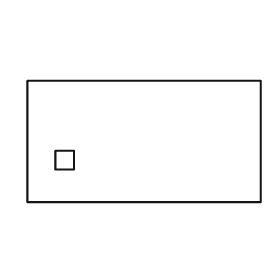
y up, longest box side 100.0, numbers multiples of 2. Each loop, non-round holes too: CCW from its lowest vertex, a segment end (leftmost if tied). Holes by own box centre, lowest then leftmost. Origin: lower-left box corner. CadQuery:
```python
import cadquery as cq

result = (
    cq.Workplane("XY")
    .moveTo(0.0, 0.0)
    .lineTo(100.0, 0.0)
    .lineTo(100.0, 52.0)
    .lineTo(0.0, 52.0)
    .close()
    .moveTo(12.0, 14.0)
    .lineTo(20.0, 14.0)
    .lineTo(20.0, 22.0)
    .lineTo(12.0, 22.0)
    .close()
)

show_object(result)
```